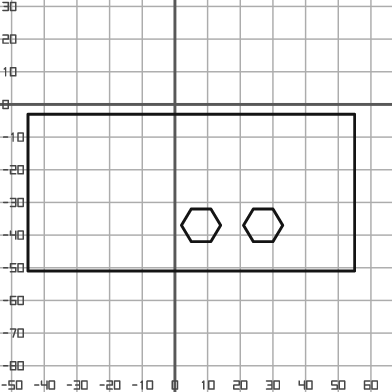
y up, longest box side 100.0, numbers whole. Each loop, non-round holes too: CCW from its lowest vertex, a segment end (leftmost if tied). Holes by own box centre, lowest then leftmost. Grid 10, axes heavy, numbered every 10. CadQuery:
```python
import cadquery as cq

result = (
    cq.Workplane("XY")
    .moveTo(-45.0, -51.0)
    .lineTo(55.0, -51.0)
    .lineTo(55.0, -3.0)
    .lineTo(-45.0, -3.0)
    .close()
    .moveTo(5.0, -42.0)
    .lineTo(11.0, -42.0)
    .lineTo(14.0, -37.0)
    .lineTo(11.0, -32.0)
    .lineTo(5.0, -32.0)
    .lineTo(2.0, -37.0)
    .close()
    .moveTo(24.0, -42.0)
    .lineTo(30.0, -42.0)
    .lineTo(33.0, -37.0)
    .lineTo(30.0, -32.0)
    .lineTo(24.0, -32.0)
    .lineTo(21.0, -37.0)
    .close()
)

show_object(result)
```